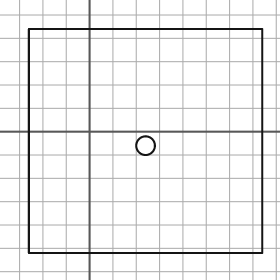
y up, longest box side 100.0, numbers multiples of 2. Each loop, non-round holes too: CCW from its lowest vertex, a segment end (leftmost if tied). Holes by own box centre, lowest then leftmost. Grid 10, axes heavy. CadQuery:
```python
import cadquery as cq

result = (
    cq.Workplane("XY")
    .moveTo(-26.0, -52.0)
    .lineTo(74.0, -52.0)
    .lineTo(74.0, 44.0)
    .lineTo(-26.0, 44.0)
    .close()
    .moveTo(24.0, -6.0)
    .circle(4.0)
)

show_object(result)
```